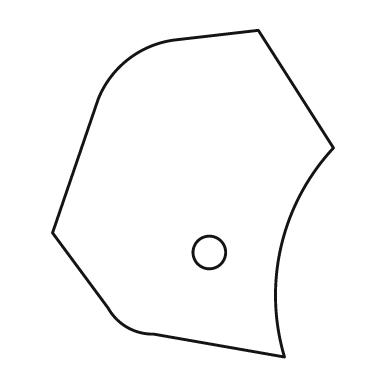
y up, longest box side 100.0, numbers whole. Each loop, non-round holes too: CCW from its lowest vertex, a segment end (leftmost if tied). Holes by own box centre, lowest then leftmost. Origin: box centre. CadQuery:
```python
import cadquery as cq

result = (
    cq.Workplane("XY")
    .moveTo(28.0, -50.0)
    .threePointArc((27.0, -16.0), (43.0, 14.0))
    .lineTo(20.0, 50.0)
    .lineTo(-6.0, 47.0)
    .threePointArc((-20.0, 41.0), (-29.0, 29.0))
    .lineTo(-43.0, -12.0)
    .lineTo(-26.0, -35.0)
    .threePointArc((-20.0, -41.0), (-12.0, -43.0))
    .close()
    .moveTo(5.0, -18.0)
    .circle(5.0)
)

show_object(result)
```